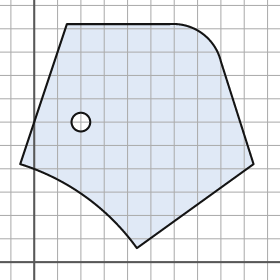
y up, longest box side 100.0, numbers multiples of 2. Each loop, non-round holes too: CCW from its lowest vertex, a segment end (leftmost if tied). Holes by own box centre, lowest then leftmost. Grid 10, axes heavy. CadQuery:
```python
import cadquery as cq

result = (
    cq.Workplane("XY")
    .moveTo(44.0, 6.0)
    .lineTo(94.0, 42.0)
    .lineTo(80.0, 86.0)
    .threePointArc((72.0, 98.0), (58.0, 102.0))
    .lineTo(14.0, 102.0)
    .lineTo(-6.0, 42.0)
    .threePointArc((22.0, 28.0), (44.0, 6.0))
    .close()
    .moveTo(20.0, 60.0)
    .circle(4.0)
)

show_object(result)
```